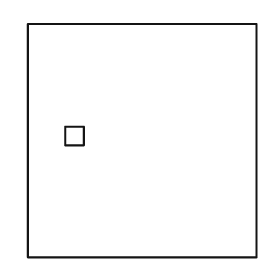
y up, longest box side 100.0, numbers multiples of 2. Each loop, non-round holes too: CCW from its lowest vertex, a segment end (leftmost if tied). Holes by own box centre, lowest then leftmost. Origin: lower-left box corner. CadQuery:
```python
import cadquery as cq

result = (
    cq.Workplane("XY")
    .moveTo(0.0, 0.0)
    .lineTo(98.0, 0.0)
    .lineTo(98.0, 100.0)
    .lineTo(0.0, 100.0)
    .close()
    .moveTo(16.0, 48.0)
    .lineTo(24.0, 48.0)
    .lineTo(24.0, 56.0)
    .lineTo(16.0, 56.0)
    .close()
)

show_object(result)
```